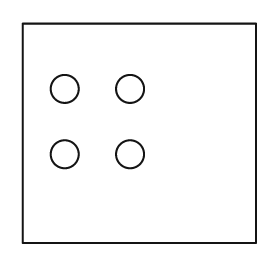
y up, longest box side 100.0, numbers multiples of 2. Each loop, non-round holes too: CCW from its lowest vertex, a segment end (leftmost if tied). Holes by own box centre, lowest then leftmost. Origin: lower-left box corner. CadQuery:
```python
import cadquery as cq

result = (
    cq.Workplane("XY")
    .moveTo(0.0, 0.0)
    .lineTo(100.0, 0.0)
    .lineTo(100.0, 94.0)
    .lineTo(0.0, 94.0)
    .close()
    .moveTo(18.0, 38.0)
    .circle(6.0)
    .moveTo(46.0, 38.0)
    .circle(6.0)
    .moveTo(18.0, 66.0)
    .circle(6.0)
    .moveTo(46.0, 66.0)
    .circle(6.0)
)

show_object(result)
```